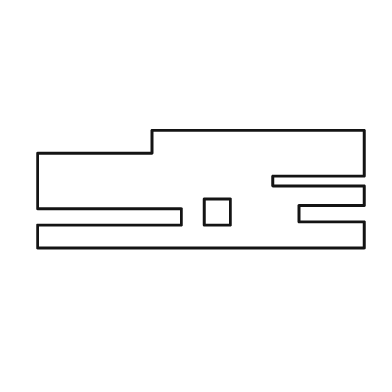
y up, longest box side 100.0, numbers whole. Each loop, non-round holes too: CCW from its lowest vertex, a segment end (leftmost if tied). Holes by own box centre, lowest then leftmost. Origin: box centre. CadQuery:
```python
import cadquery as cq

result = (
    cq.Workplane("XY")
    .moveTo(-50.0, -18.0)
    .lineTo(50.0, -18.0)
    .lineTo(50.0, -10.0)
    .lineTo(30.0, -10.0)
    .lineTo(30.0, -5.0)
    .lineTo(50.0, -5.0)
    .lineTo(50.0, 1.0)
    .lineTo(22.0, 1.0)
    .lineTo(22.0, 4.0)
    .lineTo(50.0, 4.0)
    .lineTo(50.0, 18.0)
    .lineTo(-15.0, 18.0)
    .lineTo(-15.0, 11.0)
    .lineTo(-50.0, 11.0)
    .lineTo(-50.0, -6.0)
    .lineTo(-6.0, -6.0)
    .lineTo(-6.0, -11.0)
    .lineTo(-50.0, -11.0)
    .close()
    .moveTo(1.0, -11.0)
    .lineTo(9.0, -11.0)
    .lineTo(9.0, -3.0)
    .lineTo(1.0, -3.0)
    .close()
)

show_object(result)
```